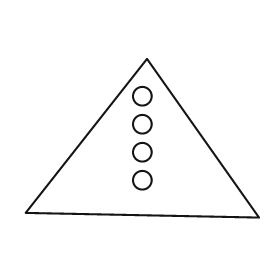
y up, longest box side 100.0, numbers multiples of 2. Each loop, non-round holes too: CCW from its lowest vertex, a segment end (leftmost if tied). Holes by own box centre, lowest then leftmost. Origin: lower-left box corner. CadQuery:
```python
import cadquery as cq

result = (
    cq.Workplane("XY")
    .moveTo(100.0, 0.0)
    .lineTo(52.0, 68.0)
    .lineTo(0.0, 2.0)
    .close()
    .moveTo(50.0, 16.0)
    .circle(4.0)
    .moveTo(50.0, 28.0)
    .circle(4.0)
    .moveTo(50.0, 40.0)
    .circle(4.0)
    .moveTo(50.0, 52.0)
    .circle(4.0)
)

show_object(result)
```